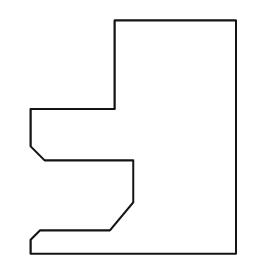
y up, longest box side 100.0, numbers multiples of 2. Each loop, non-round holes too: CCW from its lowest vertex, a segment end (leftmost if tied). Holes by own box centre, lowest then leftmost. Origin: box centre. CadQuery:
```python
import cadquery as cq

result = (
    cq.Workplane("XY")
    .moveTo(-44.0, -50.0)
    .lineTo(44.0, -50.0)
    .lineTo(44.0, 50.0)
    .lineTo(-8.0, 50.0)
    .lineTo(-8.0, 12.0)
    .lineTo(-44.0, 12.0)
    .lineTo(-44.0, -4.0)
    .lineTo(-38.0, -10.0)
    .lineTo(0.0, -10.0)
    .lineTo(0.0, -28.0)
    .lineTo(-10.0, -40.0)
    .lineTo(-40.0, -40.0)
    .lineTo(-44.0, -44.0)
    .close()
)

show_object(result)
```